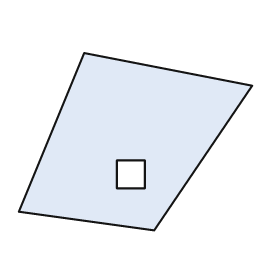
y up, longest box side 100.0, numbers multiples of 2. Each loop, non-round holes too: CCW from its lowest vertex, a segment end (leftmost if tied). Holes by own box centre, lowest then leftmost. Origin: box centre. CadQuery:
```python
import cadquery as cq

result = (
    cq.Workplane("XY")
    .moveTo(8.0, -38.0)
    .lineTo(50.0, 24.0)
    .lineTo(-22.0, 38.0)
    .lineTo(-50.0, -30.0)
    .close()
    .moveTo(-8.0, -20.0)
    .lineTo(4.0, -20.0)
    .lineTo(4.0, -8.0)
    .lineTo(-8.0, -8.0)
    .close()
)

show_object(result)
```